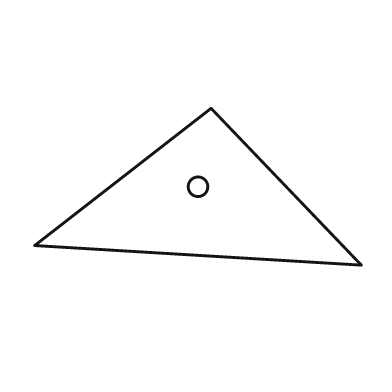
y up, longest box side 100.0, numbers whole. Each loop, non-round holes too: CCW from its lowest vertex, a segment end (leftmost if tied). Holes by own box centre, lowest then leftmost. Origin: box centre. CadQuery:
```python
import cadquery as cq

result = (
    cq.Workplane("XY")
    .moveTo(50.0, -24.0)
    .lineTo(4.0, 24.0)
    .lineTo(-50.0, -18.0)
    .close()
    .moveTo(0.0, 0.0)
    .circle(3.0)
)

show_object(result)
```